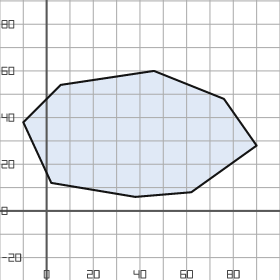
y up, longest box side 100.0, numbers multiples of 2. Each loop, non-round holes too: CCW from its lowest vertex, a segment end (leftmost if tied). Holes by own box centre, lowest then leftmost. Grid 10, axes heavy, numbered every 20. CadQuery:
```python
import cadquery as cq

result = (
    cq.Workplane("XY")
    .moveTo(38.0, 6.0)
    .lineTo(62.0, 8.0)
    .lineTo(90.0, 28.0)
    .lineTo(76.0, 48.0)
    .lineTo(46.0, 60.0)
    .lineTo(6.0, 54.0)
    .lineTo(-10.0, 38.0)
    .lineTo(2.0, 12.0)
    .close()
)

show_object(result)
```